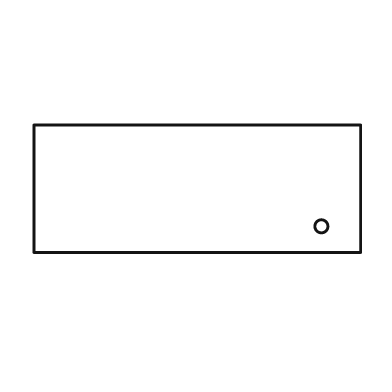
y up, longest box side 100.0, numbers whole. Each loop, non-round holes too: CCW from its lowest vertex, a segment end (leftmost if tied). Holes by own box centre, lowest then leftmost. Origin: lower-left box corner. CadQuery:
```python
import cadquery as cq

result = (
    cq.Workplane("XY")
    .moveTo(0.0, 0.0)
    .lineTo(100.0, 0.0)
    .lineTo(100.0, 39.0)
    .lineTo(0.0, 39.0)
    .close()
    .moveTo(88.0, 8.0)
    .circle(2.0)
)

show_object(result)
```